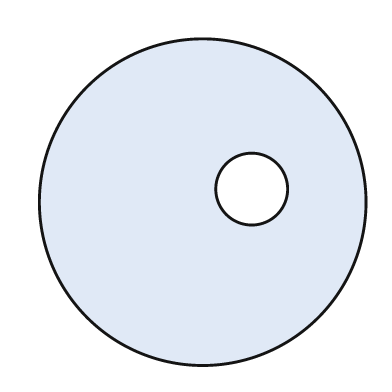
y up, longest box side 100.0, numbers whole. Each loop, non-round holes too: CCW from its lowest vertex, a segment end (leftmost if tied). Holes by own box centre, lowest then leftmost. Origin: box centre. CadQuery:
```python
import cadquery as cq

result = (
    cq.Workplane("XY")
    .moveTo(0.0, 0.0)
    .circle(50.0)
    .moveTo(15.0, 4.0)
    .circle(11.0)
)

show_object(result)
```